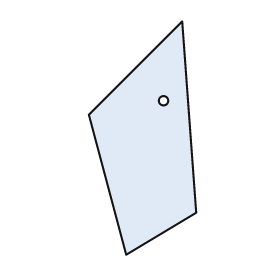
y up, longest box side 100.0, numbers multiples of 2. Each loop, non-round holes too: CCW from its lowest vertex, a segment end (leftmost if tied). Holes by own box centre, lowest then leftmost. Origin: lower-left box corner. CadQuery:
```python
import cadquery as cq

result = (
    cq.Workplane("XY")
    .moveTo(16.0, 0.0)
    .lineTo(46.0, 18.0)
    .lineTo(40.0, 100.0)
    .lineTo(0.0, 60.0)
    .close()
    .moveTo(32.0, 66.0)
    .circle(2.0)
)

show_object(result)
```